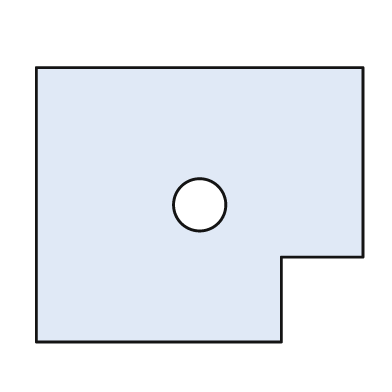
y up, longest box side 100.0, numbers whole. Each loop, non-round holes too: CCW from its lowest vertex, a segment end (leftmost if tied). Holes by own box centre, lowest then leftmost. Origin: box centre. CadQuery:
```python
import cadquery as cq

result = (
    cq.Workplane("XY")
    .moveTo(-50.0, -42.0)
    .lineTo(25.0, -42.0)
    .lineTo(25.0, -16.0)
    .lineTo(50.0, -16.0)
    .lineTo(50.0, 42.0)
    .lineTo(-50.0, 42.0)
    .close()
    .moveTo(0.0, 0.0)
    .circle(8.0)
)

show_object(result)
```